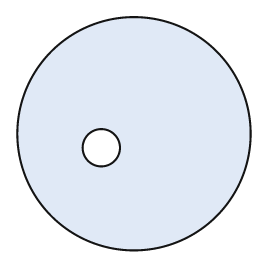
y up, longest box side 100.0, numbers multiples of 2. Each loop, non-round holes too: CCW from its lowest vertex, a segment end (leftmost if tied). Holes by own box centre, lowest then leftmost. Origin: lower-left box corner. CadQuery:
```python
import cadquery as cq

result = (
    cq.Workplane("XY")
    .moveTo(50.0, 50.0)
    .circle(50.0)
    .moveTo(36.0, 44.0)
    .circle(8.0)
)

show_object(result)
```